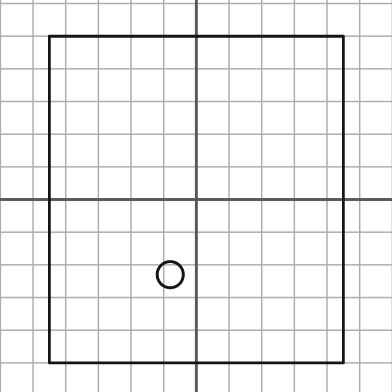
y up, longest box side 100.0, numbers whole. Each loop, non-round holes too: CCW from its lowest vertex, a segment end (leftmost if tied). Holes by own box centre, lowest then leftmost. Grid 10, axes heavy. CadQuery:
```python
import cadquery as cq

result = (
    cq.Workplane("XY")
    .moveTo(-45.0, -50.0)
    .lineTo(45.0, -50.0)
    .lineTo(45.0, 50.0)
    .lineTo(-45.0, 50.0)
    .close()
    .moveTo(-8.0, -23.0)
    .circle(4.0)
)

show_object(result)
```